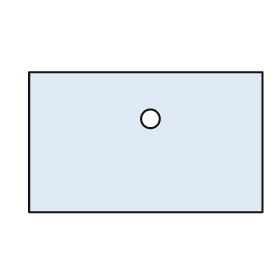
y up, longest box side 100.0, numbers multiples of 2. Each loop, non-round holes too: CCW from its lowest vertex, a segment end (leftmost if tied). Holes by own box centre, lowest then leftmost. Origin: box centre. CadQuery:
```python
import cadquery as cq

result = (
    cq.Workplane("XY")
    .moveTo(-50.0, -30.0)
    .lineTo(50.0, -30.0)
    .lineTo(50.0, 30.0)
    .lineTo(-50.0, 30.0)
    .close()
    .moveTo(2.0, 10.0)
    .circle(4.0)
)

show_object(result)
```